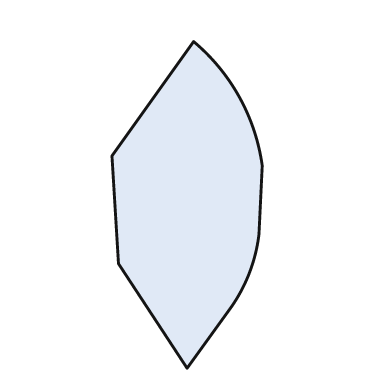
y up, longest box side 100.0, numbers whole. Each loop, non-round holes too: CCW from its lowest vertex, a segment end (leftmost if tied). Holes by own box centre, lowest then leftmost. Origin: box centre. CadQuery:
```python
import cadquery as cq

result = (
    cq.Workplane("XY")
    .moveTo(0.0, -50.0)
    .lineTo(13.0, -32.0)
    .threePointArc((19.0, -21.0), (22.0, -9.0))
    .lineTo(23.0, 12.0)
    .threePointArc((16.0, 33.0), (2.0, 50.0))
    .lineTo(-23.0, 15.0)
    .lineTo(-21.0, -18.0)
    .close()
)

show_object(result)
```